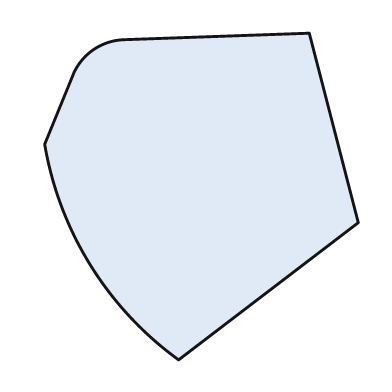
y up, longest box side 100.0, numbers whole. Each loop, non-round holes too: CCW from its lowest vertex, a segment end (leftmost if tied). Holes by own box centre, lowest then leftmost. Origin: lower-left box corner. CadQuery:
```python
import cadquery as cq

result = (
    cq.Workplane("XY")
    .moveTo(41.0, 0.0)
    .lineTo(96.0, 42.0)
    .lineTo(81.0, 100.0)
    .lineTo(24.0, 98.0)
    .threePointArc((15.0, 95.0), (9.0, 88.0))
    .lineTo(0.0, 66.0)
    .threePointArc((14.0, 29.0), (41.0, 0.0))
    .close()
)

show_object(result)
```